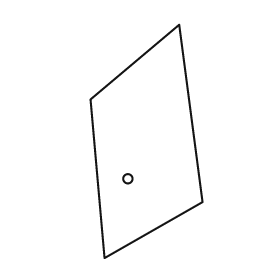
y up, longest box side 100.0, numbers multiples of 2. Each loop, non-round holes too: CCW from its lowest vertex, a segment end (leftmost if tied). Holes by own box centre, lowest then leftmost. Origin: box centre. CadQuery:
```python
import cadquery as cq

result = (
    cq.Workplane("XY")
    .moveTo(-18.0, -50.0)
    .lineTo(24.0, -26.0)
    .lineTo(14.0, 50.0)
    .lineTo(-24.0, 18.0)
    .close()
    .moveTo(-8.0, -16.0)
    .circle(2.0)
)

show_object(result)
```